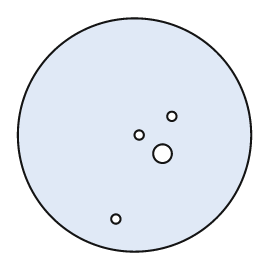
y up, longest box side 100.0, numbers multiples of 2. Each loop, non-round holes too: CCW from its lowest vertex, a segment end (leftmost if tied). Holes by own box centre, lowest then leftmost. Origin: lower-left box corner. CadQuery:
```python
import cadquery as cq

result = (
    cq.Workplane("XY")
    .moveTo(50.0, 50.0)
    .circle(50.0)
    .moveTo(42.0, 14.0)
    .circle(2.0)
    .moveTo(62.0, 42.0)
    .circle(4.0)
    .moveTo(52.0, 50.0)
    .circle(2.0)
    .moveTo(66.0, 58.0)
    .circle(2.0)
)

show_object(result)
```